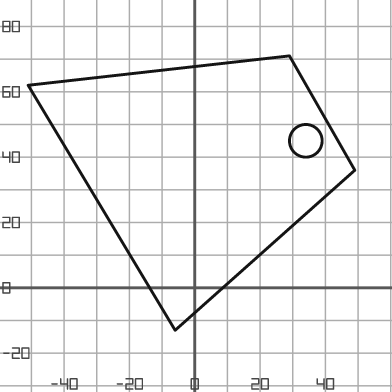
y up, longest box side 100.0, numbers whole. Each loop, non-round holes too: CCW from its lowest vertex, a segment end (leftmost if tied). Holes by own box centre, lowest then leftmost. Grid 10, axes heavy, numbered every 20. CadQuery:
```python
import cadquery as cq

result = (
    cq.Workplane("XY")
    .moveTo(-6.0, -13.0)
    .lineTo(49.0, 36.0)
    .lineTo(29.0, 71.0)
    .lineTo(-51.0, 62.0)
    .close()
    .moveTo(34.0, 45.0)
    .circle(5.0)
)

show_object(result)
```